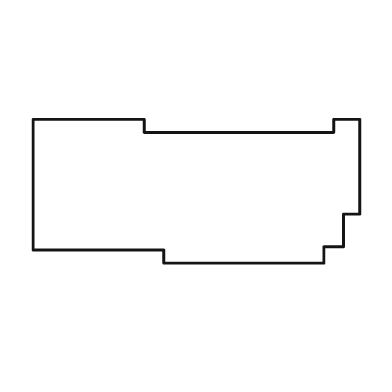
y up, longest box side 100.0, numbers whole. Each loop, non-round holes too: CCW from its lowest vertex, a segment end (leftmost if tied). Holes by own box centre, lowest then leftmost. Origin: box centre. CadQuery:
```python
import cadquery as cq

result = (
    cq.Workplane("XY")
    .moveTo(-10.0, -22.0)
    .lineTo(39.0, -22.0)
    .lineTo(39.0, -17.0)
    .lineTo(45.0, -17.0)
    .lineTo(45.0, -7.0)
    .lineTo(50.0, -7.0)
    .lineTo(50.0, 22.0)
    .lineTo(42.0, 22.0)
    .lineTo(42.0, 18.0)
    .lineTo(-16.0, 18.0)
    .lineTo(-16.0, 22.0)
    .lineTo(-50.0, 22.0)
    .lineTo(-50.0, -18.0)
    .lineTo(-10.0, -18.0)
    .close()
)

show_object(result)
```